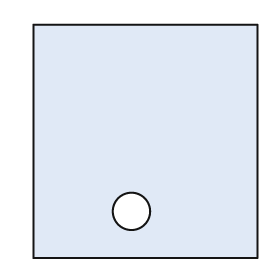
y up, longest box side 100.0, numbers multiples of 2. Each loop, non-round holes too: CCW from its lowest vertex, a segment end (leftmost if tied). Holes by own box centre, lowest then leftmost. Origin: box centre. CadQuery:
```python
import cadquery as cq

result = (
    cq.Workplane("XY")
    .moveTo(-48.0, -50.0)
    .lineTo(48.0, -50.0)
    .lineTo(48.0, 50.0)
    .lineTo(-48.0, 50.0)
    .close()
    .moveTo(-6.0, -30.0)
    .circle(8.0)
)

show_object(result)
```